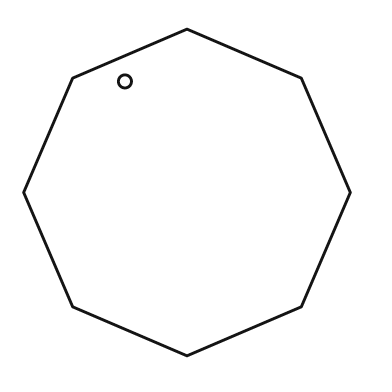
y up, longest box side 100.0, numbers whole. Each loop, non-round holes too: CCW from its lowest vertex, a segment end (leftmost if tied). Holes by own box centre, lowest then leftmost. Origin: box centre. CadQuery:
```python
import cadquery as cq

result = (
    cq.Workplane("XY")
    .moveTo(0.0, -50.0)
    .lineTo(35.0, -35.0)
    .lineTo(50.0, 0.0)
    .lineTo(35.0, 35.0)
    .lineTo(0.0, 50.0)
    .lineTo(-35.0, 35.0)
    .lineTo(-50.0, 0.0)
    .lineTo(-35.0, -35.0)
    .close()
    .moveTo(-19.0, 34.0)
    .circle(2.0)
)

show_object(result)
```